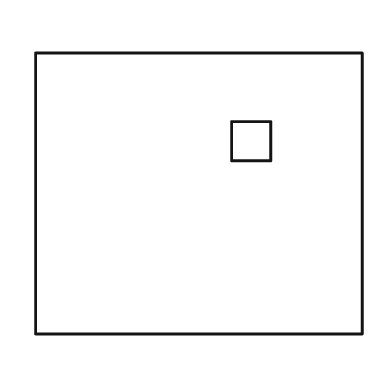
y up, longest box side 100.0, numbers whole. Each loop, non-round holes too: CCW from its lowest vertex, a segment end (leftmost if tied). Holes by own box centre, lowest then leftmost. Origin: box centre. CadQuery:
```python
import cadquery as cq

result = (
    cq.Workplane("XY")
    .moveTo(-50.0, -43.0)
    .lineTo(50.0, -43.0)
    .lineTo(50.0, 43.0)
    .lineTo(-50.0, 43.0)
    .close()
    .moveTo(10.0, 10.0)
    .lineTo(22.0, 10.0)
    .lineTo(22.0, 22.0)
    .lineTo(10.0, 22.0)
    .close()
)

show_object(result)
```